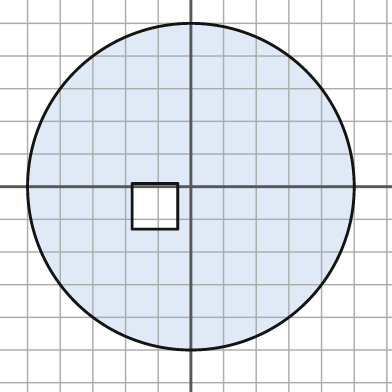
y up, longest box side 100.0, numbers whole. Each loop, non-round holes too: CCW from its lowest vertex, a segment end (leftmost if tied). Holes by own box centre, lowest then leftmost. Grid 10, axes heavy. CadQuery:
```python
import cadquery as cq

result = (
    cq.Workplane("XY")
    .moveTo(0.0, 0.0)
    .circle(50.0)
    .moveTo(-18.0, -13.0)
    .lineTo(-4.0, -13.0)
    .lineTo(-4.0, 1.0)
    .lineTo(-18.0, 1.0)
    .close()
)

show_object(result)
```